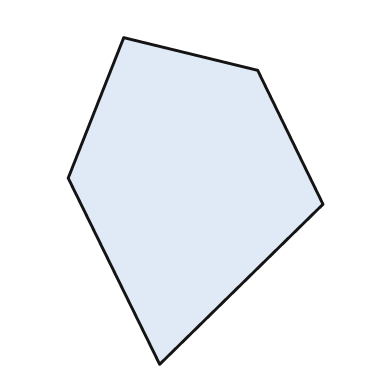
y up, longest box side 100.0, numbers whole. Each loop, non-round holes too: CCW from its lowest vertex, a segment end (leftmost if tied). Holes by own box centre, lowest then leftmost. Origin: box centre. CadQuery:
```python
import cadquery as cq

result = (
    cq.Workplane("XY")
    .moveTo(-11.0, -50.0)
    .lineTo(39.0, -1.0)
    .lineTo(19.0, 40.0)
    .lineTo(-22.0, 50.0)
    .lineTo(-39.0, 7.0)
    .close()
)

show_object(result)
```